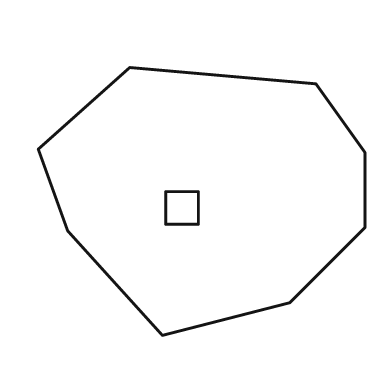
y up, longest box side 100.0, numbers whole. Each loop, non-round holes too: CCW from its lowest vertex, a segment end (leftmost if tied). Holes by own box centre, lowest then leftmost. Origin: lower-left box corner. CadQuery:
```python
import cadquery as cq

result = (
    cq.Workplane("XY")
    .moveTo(38.0, 0.0)
    .lineTo(77.0, 10.0)
    .lineTo(100.0, 33.0)
    .lineTo(100.0, 56.0)
    .lineTo(85.0, 77.0)
    .lineTo(28.0, 82.0)
    .lineTo(0.0, 57.0)
    .lineTo(9.0, 32.0)
    .close()
    .moveTo(39.0, 34.0)
    .lineTo(49.0, 34.0)
    .lineTo(49.0, 44.0)
    .lineTo(39.0, 44.0)
    .close()
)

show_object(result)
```